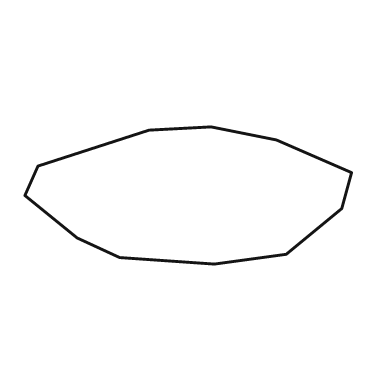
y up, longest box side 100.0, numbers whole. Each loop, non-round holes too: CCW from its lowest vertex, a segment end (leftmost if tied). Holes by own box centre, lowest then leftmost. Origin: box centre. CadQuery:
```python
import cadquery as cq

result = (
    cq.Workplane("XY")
    .moveTo(8.0, -21.0)
    .lineTo(30.0, -18.0)
    .lineTo(47.0, -4.0)
    .lineTo(50.0, 7.0)
    .lineTo(27.0, 17.0)
    .lineTo(7.0, 21.0)
    .lineTo(-12.0, 20.0)
    .lineTo(-46.0, 9.0)
    .lineTo(-50.0, 0.0)
    .lineTo(-34.0, -13.0)
    .lineTo(-21.0, -19.0)
    .close()
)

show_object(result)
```